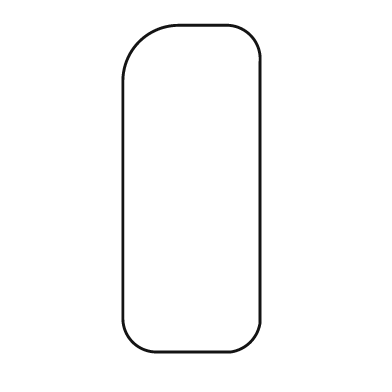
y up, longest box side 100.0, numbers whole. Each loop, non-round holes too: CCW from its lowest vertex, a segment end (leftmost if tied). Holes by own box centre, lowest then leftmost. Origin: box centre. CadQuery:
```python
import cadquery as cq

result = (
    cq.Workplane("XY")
    .moveTo(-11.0, -50.0)
    .lineTo(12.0, -50.0)
    .threePointArc((18.0, -47.0), (21.0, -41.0))
    .lineTo(21.0, 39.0)
    .threePointArc((18.0, 47.0), (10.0, 50.0))
    .lineTo(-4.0, 50.0)
    .threePointArc((-16.0, 45.0), (-21.0, 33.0))
    .lineTo(-21.0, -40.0)
    .threePointArc((-18.0, -47.0), (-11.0, -50.0))
    .close()
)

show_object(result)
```